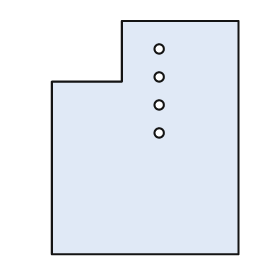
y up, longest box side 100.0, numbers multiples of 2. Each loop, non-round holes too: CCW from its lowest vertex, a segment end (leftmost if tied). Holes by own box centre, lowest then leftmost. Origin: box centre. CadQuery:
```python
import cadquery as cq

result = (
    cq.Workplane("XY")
    .moveTo(-40.0, -50.0)
    .lineTo(40.0, -50.0)
    .lineTo(40.0, 50.0)
    .lineTo(-10.0, 50.0)
    .lineTo(-10.0, 24.0)
    .lineTo(-40.0, 24.0)
    .close()
    .moveTo(6.0, 2.0)
    .circle(2.0)
    .moveTo(6.0, 14.0)
    .circle(2.0)
    .moveTo(6.0, 26.0)
    .circle(2.0)
    .moveTo(6.0, 38.0)
    .circle(2.0)
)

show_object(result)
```